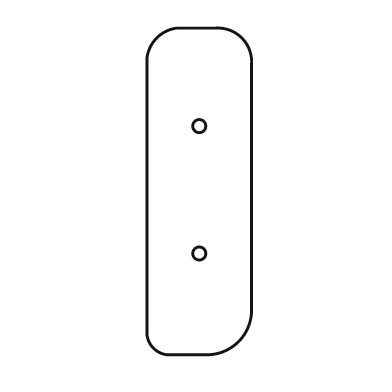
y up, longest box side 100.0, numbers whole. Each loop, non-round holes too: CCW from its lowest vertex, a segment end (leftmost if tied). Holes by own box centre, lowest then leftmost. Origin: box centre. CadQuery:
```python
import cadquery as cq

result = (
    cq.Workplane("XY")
    .moveTo(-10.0, -50.0)
    .lineTo(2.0, -50.0)
    .threePointArc((12.0, -46.0), (16.0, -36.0))
    .lineTo(16.0, 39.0)
    .threePointArc((13.0, 47.0), (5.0, 50.0))
    .lineTo(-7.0, 50.0)
    .threePointArc((-13.0, 47.0), (-16.0, 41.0))
    .lineTo(-16.0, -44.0)
    .threePointArc((-14.0, -48.0), (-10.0, -50.0))
    .close()
    .moveTo(0.0, -19.0)
    .circle(2.0)
    .moveTo(0.0, 20.0)
    .circle(2.0)
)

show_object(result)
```